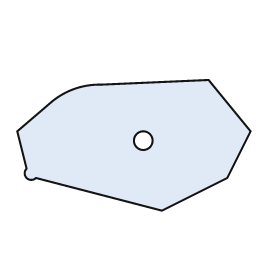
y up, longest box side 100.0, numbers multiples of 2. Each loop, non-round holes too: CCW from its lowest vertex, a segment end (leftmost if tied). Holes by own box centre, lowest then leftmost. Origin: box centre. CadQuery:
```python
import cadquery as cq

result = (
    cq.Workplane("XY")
    .moveTo(12.0, -28.0)
    .lineTo(40.0, -14.0)
    .lineTo(50.0, 6.0)
    .lineTo(32.0, 28.0)
    .lineTo(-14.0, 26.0)
    .threePointArc((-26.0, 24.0), (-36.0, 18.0))
    .lineTo(-50.0, 6.0)
    .lineTo(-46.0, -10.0)
    .threePointArc((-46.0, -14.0), (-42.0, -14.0))
    .close()
    .moveTo(4.0, 2.0)
    .circle(4.0)
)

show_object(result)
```